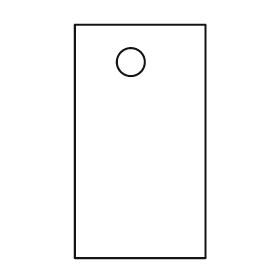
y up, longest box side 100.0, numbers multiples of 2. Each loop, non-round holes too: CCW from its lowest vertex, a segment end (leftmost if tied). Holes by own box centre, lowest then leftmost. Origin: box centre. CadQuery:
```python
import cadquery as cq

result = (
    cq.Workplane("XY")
    .moveTo(-28.0, -50.0)
    .lineTo(28.0, -50.0)
    .lineTo(28.0, 50.0)
    .lineTo(-28.0, 50.0)
    .close()
    .moveTo(-4.0, 34.0)
    .circle(6.0)
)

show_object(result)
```